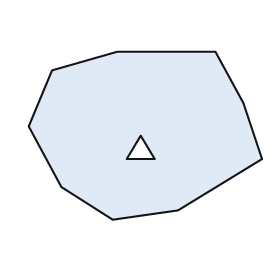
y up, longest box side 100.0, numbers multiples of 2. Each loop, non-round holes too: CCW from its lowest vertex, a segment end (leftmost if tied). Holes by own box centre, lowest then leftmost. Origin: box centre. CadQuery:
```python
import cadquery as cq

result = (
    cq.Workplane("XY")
    .moveTo(-14.0, -36.0)
    .lineTo(14.0, -32.0)
    .lineTo(50.0, -10.0)
    .lineTo(42.0, 14.0)
    .lineTo(30.0, 36.0)
    .lineTo(-12.0, 36.0)
    .lineTo(-40.0, 28.0)
    .lineTo(-50.0, 4.0)
    .lineTo(-36.0, -22.0)
    .close()
    .moveTo(-8.0, -10.0)
    .lineTo(4.0, -10.0)
    .lineTo(-2.0, 0.0)
    .close()
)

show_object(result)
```